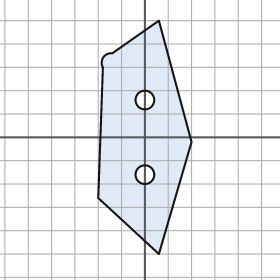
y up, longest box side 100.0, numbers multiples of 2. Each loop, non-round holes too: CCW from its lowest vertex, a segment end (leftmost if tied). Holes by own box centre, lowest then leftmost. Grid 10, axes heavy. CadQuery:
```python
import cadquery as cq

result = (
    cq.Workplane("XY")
    .moveTo(6.0, -50.0)
    .lineTo(20.0, -2.0)
    .lineTo(6.0, 50.0)
    .lineTo(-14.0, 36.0)
    .threePointArc((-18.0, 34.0), (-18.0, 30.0))
    .lineTo(-20.0, -26.0)
    .close()
    .moveTo(0.0, -16.0)
    .circle(4.0)
    .moveTo(0.0, 16.0)
    .circle(4.0)
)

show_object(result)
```